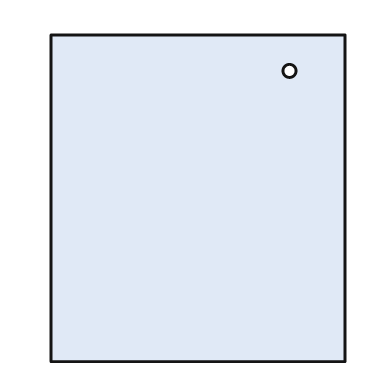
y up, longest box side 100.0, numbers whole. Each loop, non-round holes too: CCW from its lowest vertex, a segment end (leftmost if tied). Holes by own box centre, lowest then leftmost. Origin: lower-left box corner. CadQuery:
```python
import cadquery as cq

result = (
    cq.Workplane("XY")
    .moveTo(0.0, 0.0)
    .lineTo(90.0, 0.0)
    .lineTo(90.0, 100.0)
    .lineTo(0.0, 100.0)
    .close()
    .moveTo(73.0, 89.0)
    .circle(2.0)
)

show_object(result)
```